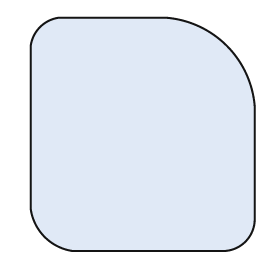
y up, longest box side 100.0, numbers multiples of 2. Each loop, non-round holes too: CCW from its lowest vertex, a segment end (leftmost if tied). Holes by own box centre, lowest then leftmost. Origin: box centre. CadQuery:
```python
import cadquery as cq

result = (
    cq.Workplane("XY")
    .moveTo(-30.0, -50.0)
    .lineTo(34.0, -50.0)
    .threePointArc((44.0, -46.0), (48.0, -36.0))
    .lineTo(48.0, 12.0)
    .threePointArc((36.0, 38.0), (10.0, 50.0))
    .lineTo(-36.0, 50.0)
    .threePointArc((-44.0, 46.0), (-48.0, 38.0))
    .lineTo(-48.0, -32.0)
    .threePointArc((-42.0, -44.0), (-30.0, -50.0))
    .close()
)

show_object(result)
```